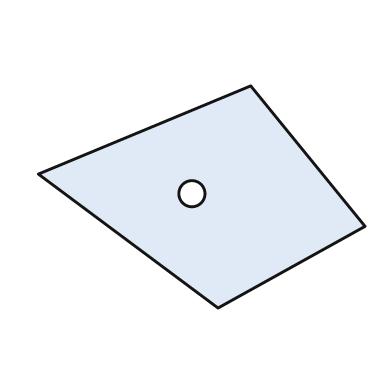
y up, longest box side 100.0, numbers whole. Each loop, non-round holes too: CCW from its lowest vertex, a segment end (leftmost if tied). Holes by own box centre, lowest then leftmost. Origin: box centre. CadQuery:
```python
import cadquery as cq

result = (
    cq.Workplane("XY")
    .moveTo(5.0, -34.0)
    .lineTo(50.0, -9.0)
    .lineTo(15.0, 34.0)
    .lineTo(-50.0, 7.0)
    .close()
    .moveTo(-3.0, 1.0)
    .circle(4.0)
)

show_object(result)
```